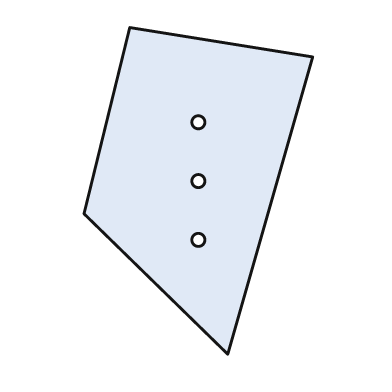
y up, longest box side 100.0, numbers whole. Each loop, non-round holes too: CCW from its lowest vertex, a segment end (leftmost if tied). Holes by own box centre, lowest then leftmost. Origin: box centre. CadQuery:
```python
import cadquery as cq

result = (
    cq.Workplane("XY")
    .moveTo(9.0, -50.0)
    .lineTo(35.0, 41.0)
    .lineTo(-21.0, 50.0)
    .lineTo(-35.0, -7.0)
    .close()
    .moveTo(0.0, -15.0)
    .circle(2.0)
    .moveTo(0.0, 3.0)
    .circle(2.0)
    .moveTo(0.0, 21.0)
    .circle(2.0)
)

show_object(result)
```